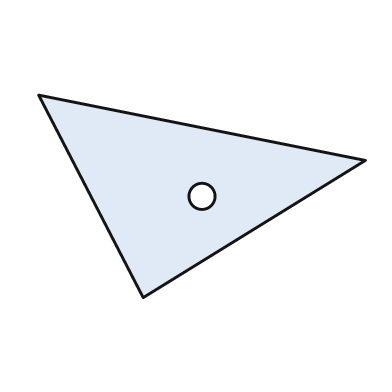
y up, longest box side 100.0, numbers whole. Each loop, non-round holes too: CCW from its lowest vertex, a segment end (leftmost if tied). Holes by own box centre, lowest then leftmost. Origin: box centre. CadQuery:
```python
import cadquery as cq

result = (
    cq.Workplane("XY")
    .moveTo(-18.0, -31.0)
    .lineTo(50.0, 11.0)
    .lineTo(-50.0, 31.0)
    .close()
    .moveTo(0.0, 0.0)
    .circle(4.0)
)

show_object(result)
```